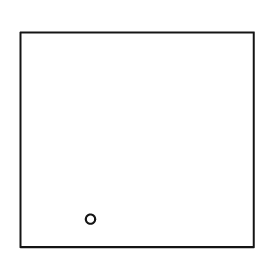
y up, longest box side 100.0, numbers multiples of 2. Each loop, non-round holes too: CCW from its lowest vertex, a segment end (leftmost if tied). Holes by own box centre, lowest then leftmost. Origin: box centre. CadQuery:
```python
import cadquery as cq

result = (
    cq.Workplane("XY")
    .moveTo(-50.0, -46.0)
    .lineTo(50.0, -46.0)
    .lineTo(50.0, 46.0)
    .lineTo(-50.0, 46.0)
    .close()
    .moveTo(-20.0, -34.0)
    .circle(2.0)
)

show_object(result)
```